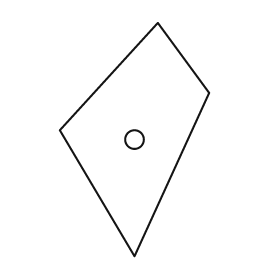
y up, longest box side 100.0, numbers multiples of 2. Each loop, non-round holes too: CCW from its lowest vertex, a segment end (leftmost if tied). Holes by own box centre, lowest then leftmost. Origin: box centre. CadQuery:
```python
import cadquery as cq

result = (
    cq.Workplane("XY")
    .moveTo(0.0, -50.0)
    .lineTo(32.0, 20.0)
    .lineTo(10.0, 50.0)
    .lineTo(-32.0, 4.0)
    .close()
    .moveTo(0.0, 0.0)
    .circle(4.0)
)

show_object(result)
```